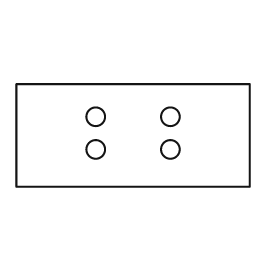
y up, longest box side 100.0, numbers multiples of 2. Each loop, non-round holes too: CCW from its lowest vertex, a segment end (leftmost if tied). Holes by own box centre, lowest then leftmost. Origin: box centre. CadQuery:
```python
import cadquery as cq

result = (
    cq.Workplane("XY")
    .moveTo(-50.0, -22.0)
    .lineTo(50.0, -22.0)
    .lineTo(50.0, 22.0)
    .lineTo(-50.0, 22.0)
    .close()
    .moveTo(-16.0, -6.0)
    .circle(4.0)
    .moveTo(16.0, -6.0)
    .circle(4.0)
    .moveTo(-16.0, 8.0)
    .circle(4.0)
    .moveTo(16.0, 8.0)
    .circle(4.0)
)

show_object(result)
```